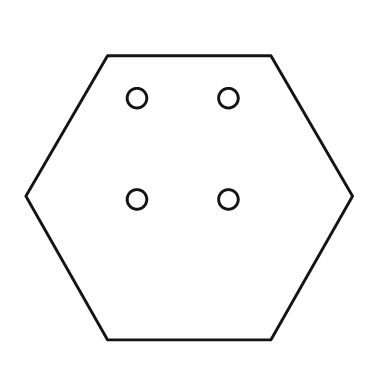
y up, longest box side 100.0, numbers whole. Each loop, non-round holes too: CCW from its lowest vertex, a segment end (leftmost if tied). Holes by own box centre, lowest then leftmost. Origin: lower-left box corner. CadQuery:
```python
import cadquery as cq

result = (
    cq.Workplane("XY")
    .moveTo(25.0, 0.0)
    .lineTo(75.0, 0.0)
    .lineTo(100.0, 44.0)
    .lineTo(75.0, 87.0)
    .lineTo(25.0, 87.0)
    .lineTo(0.0, 44.0)
    .close()
    .moveTo(34.0, 43.0)
    .circle(3.0)
    .moveTo(62.0, 43.0)
    .circle(3.0)
    .moveTo(34.0, 74.0)
    .circle(3.0)
    .moveTo(62.0, 74.0)
    .circle(3.0)
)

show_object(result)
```